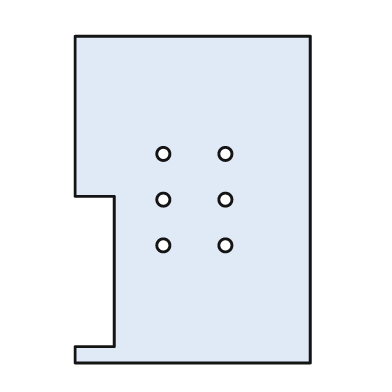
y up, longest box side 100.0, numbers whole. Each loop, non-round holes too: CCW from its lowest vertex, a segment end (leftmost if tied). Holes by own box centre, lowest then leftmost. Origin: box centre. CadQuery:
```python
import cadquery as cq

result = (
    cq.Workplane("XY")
    .moveTo(-36.0, -50.0)
    .lineTo(36.0, -50.0)
    .lineTo(36.0, 50.0)
    .lineTo(-36.0, 50.0)
    .lineTo(-36.0, 1.0)
    .lineTo(-24.0, 1.0)
    .lineTo(-24.0, -45.0)
    .lineTo(-36.0, -45.0)
    .close()
    .moveTo(-9.0, -14.0)
    .circle(2.0)
    .moveTo(10.0, -14.0)
    .circle(2.0)
    .moveTo(-9.0, 0.0)
    .circle(2.0)
    .moveTo(10.0, 0.0)
    .circle(2.0)
    .moveTo(-9.0, 14.0)
    .circle(2.0)
    .moveTo(10.0, 14.0)
    .circle(2.0)
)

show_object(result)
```